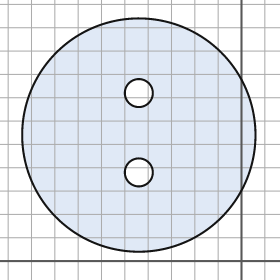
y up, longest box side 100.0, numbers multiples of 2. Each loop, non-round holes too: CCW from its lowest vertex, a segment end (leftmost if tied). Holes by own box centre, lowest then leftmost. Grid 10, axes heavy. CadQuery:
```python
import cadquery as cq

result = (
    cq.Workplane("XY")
    .moveTo(-44.0, 54.0)
    .circle(50.0)
    .moveTo(-44.0, 38.0)
    .circle(6.0)
    .moveTo(-44.0, 72.0)
    .circle(6.0)
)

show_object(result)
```